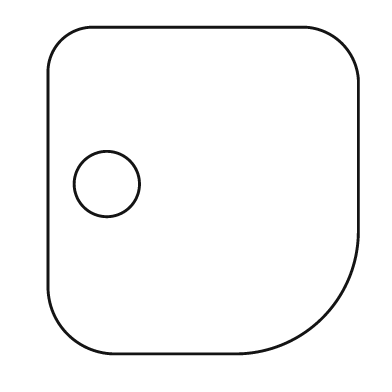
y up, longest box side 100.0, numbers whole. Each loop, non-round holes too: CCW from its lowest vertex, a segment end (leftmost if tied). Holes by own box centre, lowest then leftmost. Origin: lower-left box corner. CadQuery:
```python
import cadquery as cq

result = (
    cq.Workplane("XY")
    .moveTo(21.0, 0.0)
    .lineTo(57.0, 0.0)
    .threePointArc((84.0, 11.0), (95.0, 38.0))
    .lineTo(95.0, 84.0)
    .threePointArc((90.0, 95.0), (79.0, 100.0))
    .lineTo(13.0, 100.0)
    .threePointArc((4.0, 96.0), (0.0, 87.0))
    .lineTo(0.0, 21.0)
    .threePointArc((6.0, 6.0), (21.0, 0.0))
    .close()
    .moveTo(18.0, 52.0)
    .circle(10.0)
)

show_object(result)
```